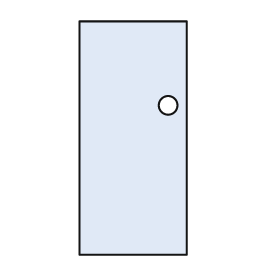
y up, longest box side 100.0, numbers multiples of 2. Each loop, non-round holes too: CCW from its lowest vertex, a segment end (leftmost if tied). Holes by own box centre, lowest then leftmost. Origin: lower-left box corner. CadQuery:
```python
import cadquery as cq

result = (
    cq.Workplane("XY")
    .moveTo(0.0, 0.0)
    .lineTo(46.0, 0.0)
    .lineTo(46.0, 100.0)
    .lineTo(0.0, 100.0)
    .close()
    .moveTo(38.0, 64.0)
    .circle(4.0)
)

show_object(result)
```